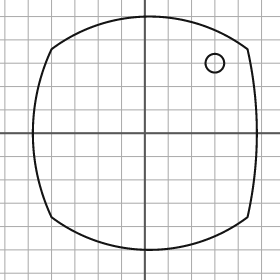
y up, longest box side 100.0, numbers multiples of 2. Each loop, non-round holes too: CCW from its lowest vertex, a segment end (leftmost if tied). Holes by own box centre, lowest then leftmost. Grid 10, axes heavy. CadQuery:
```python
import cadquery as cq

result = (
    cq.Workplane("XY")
    .moveTo(-40.0, -36.0)
    .threePointArc((2.0, -50.0), (44.0, -36.0))
    .threePointArc((48.0, 0.0), (44.0, 36.0))
    .threePointArc((2.0, 50.0), (-40.0, 36.0))
    .threePointArc((-48.0, 0.0), (-40.0, -36.0))
    .close()
    .moveTo(30.0, 30.0)
    .circle(4.0)
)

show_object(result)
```